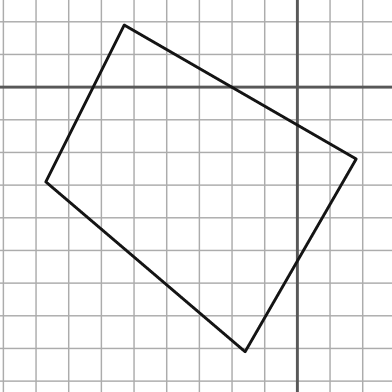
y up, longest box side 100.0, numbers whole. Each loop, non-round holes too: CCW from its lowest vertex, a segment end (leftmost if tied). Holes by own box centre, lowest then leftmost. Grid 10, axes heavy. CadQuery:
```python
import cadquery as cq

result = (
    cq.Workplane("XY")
    .moveTo(-16.0, -81.0)
    .lineTo(18.0, -22.0)
    .lineTo(-53.0, 19.0)
    .lineTo(-77.0, -29.0)
    .close()
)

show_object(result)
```